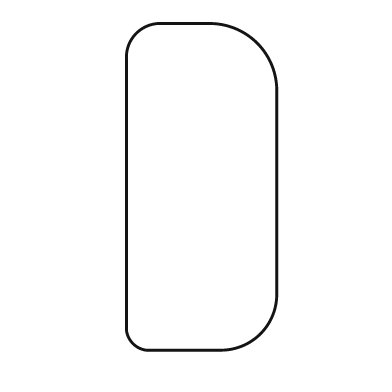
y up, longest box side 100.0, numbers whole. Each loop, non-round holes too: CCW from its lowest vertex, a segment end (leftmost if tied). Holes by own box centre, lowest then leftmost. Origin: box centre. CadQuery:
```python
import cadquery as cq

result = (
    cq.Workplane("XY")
    .moveTo(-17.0, -50.0)
    .lineTo(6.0, -50.0)
    .threePointArc((18.0, -45.0), (23.0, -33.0))
    .lineTo(23.0, 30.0)
    .threePointArc((17.0, 44.0), (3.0, 50.0))
    .lineTo(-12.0, 50.0)
    .threePointArc((-20.0, 47.0), (-23.0, 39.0))
    .lineTo(-23.0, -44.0)
    .threePointArc((-21.0, -48.0), (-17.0, -50.0))
    .close()
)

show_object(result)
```